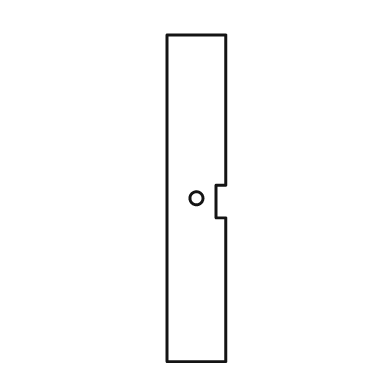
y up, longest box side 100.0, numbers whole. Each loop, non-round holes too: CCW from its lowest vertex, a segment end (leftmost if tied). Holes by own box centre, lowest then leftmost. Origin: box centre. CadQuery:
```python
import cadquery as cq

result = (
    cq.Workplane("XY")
    .moveTo(-9.0, -50.0)
    .lineTo(9.0, -50.0)
    .lineTo(9.0, -6.0)
    .lineTo(6.0, -6.0)
    .lineTo(6.0, 4.0)
    .lineTo(9.0, 4.0)
    .lineTo(9.0, 50.0)
    .lineTo(-9.0, 50.0)
    .close()
    .moveTo(0.0, 0.0)
    .circle(2.0)
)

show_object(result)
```